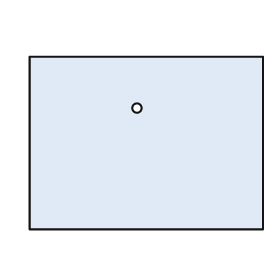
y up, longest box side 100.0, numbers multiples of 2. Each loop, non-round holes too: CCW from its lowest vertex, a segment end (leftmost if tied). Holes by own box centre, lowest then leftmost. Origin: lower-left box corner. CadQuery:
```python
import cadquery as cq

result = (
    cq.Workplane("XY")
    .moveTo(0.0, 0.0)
    .lineTo(100.0, 0.0)
    .lineTo(100.0, 74.0)
    .lineTo(0.0, 74.0)
    .close()
    .moveTo(46.0, 52.0)
    .circle(2.0)
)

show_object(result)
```